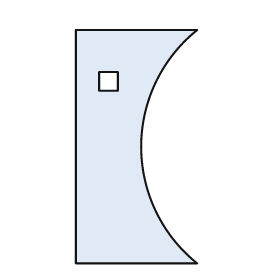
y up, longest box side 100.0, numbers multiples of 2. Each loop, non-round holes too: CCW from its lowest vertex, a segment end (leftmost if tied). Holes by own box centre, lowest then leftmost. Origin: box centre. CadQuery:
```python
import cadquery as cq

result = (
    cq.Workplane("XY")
    .moveTo(-26.0, -50.0)
    .lineTo(26.0, -50.0)
    .threePointArc((2.0, 0.0), (26.0, 50.0))
    .lineTo(-26.0, 50.0)
    .close()
    .moveTo(-16.0, 24.0)
    .lineTo(-8.0, 24.0)
    .lineTo(-8.0, 32.0)
    .lineTo(-16.0, 32.0)
    .close()
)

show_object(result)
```